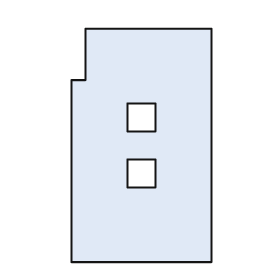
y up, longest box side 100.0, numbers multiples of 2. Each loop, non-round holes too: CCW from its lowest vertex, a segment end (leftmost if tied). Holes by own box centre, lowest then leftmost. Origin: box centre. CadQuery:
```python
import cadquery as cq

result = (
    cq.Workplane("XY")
    .moveTo(-30.0, -50.0)
    .lineTo(30.0, -50.0)
    .lineTo(30.0, 50.0)
    .lineTo(-24.0, 50.0)
    .lineTo(-24.0, 28.0)
    .lineTo(-30.0, 28.0)
    .close()
    .moveTo(-6.0, -18.0)
    .lineTo(6.0, -18.0)
    .lineTo(6.0, -6.0)
    .lineTo(-6.0, -6.0)
    .close()
    .moveTo(-6.0, 6.0)
    .lineTo(6.0, 6.0)
    .lineTo(6.0, 18.0)
    .lineTo(-6.0, 18.0)
    .close()
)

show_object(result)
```